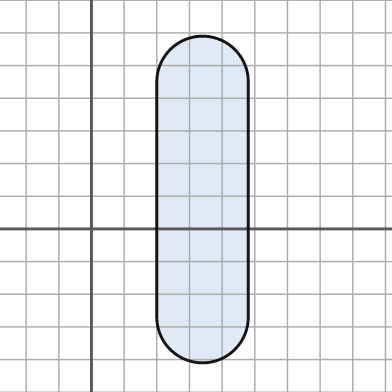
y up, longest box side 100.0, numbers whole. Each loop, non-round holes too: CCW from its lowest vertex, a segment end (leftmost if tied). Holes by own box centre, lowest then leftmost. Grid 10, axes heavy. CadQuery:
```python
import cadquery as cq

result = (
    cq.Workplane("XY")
    .moveTo(20.0, -27.0)
    .threePointArc((34.0, -41.0), (48.0, -27.0))
    .lineTo(48.0, 45.0)
    .threePointArc((34.0, 59.0), (20.0, 45.0))
    .close()
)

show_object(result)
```